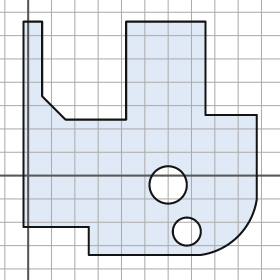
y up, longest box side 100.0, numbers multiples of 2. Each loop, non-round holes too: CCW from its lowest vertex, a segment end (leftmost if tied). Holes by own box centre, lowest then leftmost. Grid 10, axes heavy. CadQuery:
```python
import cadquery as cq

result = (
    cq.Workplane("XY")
    .moveTo(26.0, -34.0)
    .lineTo(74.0, -34.0)
    .threePointArc((90.0, -26.0), (98.0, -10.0))
    .lineTo(98.0, 26.0)
    .lineTo(76.0, 26.0)
    .lineTo(76.0, 66.0)
    .lineTo(42.0, 66.0)
    .lineTo(42.0, 24.0)
    .lineTo(16.0, 24.0)
    .lineTo(6.0, 34.0)
    .lineTo(6.0, 66.0)
    .lineTo(-2.0, 66.0)
    .lineTo(-2.0, -22.0)
    .lineTo(26.0, -22.0)
    .close()
    .moveTo(68.0, -24.0)
    .circle(6.0)
    .moveTo(60.0, -4.0)
    .circle(8.0)
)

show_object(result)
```